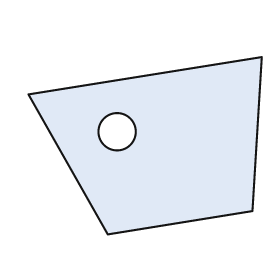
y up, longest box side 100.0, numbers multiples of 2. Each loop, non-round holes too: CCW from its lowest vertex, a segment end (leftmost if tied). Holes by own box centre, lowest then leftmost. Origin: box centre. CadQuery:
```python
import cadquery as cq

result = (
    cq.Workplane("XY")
    .moveTo(-16.0, -38.0)
    .lineTo(46.0, -28.0)
    .lineTo(50.0, 38.0)
    .lineTo(-50.0, 22.0)
    .close()
    .moveTo(-12.0, 6.0)
    .circle(8.0)
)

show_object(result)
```